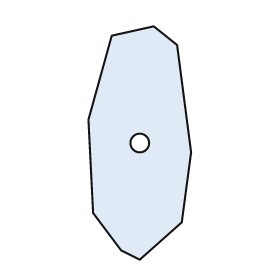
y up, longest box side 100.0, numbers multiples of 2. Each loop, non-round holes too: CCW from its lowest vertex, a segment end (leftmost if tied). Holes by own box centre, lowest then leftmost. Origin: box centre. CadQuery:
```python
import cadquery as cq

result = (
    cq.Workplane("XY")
    .moveTo(0.0, -50.0)
    .lineTo(18.0, -34.0)
    .lineTo(22.0, -4.0)
    .lineTo(16.0, 42.0)
    .lineTo(6.0, 50.0)
    .lineTo(-12.0, 46.0)
    .lineTo(-22.0, 10.0)
    .lineTo(-20.0, -30.0)
    .lineTo(-8.0, -46.0)
    .close()
    .moveTo(0.0, 0.0)
    .circle(4.0)
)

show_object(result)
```